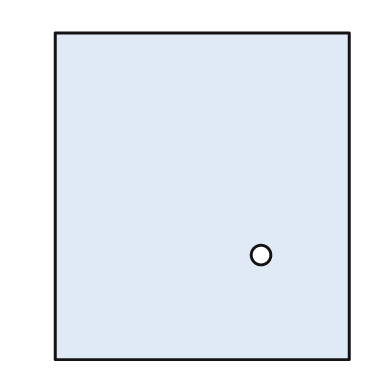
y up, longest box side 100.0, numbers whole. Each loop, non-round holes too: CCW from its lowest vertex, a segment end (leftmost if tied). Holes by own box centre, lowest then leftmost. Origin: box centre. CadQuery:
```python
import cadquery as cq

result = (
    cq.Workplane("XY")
    .moveTo(-45.0, -50.0)
    .lineTo(45.0, -50.0)
    .lineTo(45.0, 50.0)
    .lineTo(-45.0, 50.0)
    .close()
    .moveTo(18.0, -18.0)
    .circle(3.0)
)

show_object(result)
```